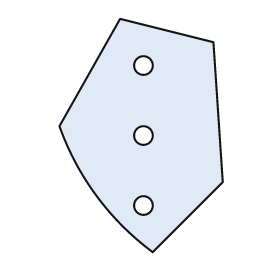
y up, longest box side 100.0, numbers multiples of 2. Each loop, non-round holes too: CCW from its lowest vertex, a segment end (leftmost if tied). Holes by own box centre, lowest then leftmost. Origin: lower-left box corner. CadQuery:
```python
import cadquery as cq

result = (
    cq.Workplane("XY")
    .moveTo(40.0, 0.0)
    .lineTo(70.0, 30.0)
    .lineTo(66.0, 90.0)
    .lineTo(26.0, 100.0)
    .lineTo(0.0, 54.0)
    .threePointArc((16.0, 24.0), (40.0, 0.0))
    .close()
    .moveTo(36.0, 20.0)
    .circle(4.0)
    .moveTo(36.0, 50.0)
    .circle(4.0)
    .moveTo(36.0, 80.0)
    .circle(4.0)
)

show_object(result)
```